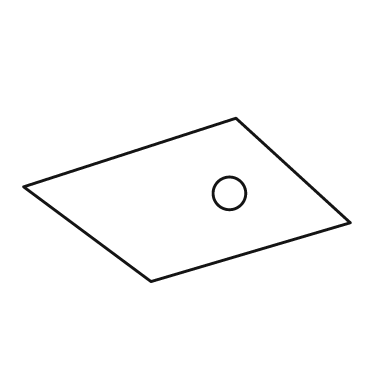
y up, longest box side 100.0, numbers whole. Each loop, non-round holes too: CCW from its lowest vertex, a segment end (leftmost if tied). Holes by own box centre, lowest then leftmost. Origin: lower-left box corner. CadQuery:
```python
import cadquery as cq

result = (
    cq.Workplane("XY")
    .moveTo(39.0, 0.0)
    .lineTo(100.0, 18.0)
    .lineTo(65.0, 50.0)
    .lineTo(0.0, 29.0)
    .close()
    .moveTo(63.0, 27.0)
    .circle(5.0)
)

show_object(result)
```